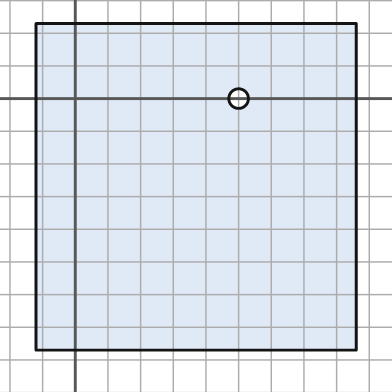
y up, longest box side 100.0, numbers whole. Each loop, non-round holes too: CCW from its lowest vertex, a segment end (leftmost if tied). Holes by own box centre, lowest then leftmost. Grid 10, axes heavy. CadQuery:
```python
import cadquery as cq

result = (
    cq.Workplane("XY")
    .moveTo(-12.0, -77.0)
    .lineTo(86.0, -77.0)
    .lineTo(86.0, 23.0)
    .lineTo(-12.0, 23.0)
    .close()
    .moveTo(50.0, 0.0)
    .circle(3.0)
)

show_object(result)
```